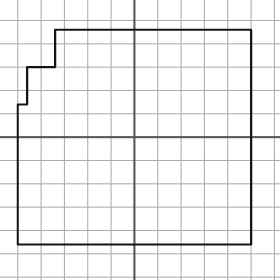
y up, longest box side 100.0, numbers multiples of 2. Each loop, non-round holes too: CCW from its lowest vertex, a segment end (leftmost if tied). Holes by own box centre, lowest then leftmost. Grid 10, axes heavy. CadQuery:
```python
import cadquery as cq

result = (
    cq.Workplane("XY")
    .moveTo(-50.0, -46.0)
    .lineTo(50.0, -46.0)
    .lineTo(50.0, 46.0)
    .lineTo(-34.0, 46.0)
    .lineTo(-34.0, 30.0)
    .lineTo(-46.0, 30.0)
    .lineTo(-46.0, 14.0)
    .lineTo(-50.0, 14.0)
    .close()
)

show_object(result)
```